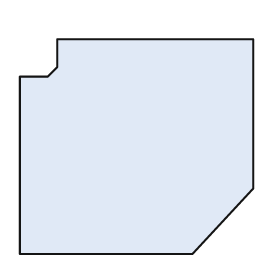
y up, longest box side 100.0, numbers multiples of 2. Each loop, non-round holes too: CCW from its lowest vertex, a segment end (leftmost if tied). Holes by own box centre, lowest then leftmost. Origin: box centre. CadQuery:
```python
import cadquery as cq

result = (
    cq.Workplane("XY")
    .moveTo(-50.0, -46.0)
    .lineTo(24.0, -46.0)
    .lineTo(50.0, -18.0)
    .lineTo(50.0, 46.0)
    .lineTo(-34.0, 46.0)
    .lineTo(-34.0, 34.0)
    .lineTo(-38.0, 30.0)
    .lineTo(-50.0, 30.0)
    .close()
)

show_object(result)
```